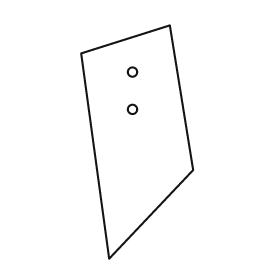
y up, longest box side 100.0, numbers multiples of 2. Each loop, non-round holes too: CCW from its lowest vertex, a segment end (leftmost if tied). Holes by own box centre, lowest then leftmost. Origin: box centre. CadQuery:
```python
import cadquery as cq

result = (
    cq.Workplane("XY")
    .moveTo(-12.0, -50.0)
    .lineTo(24.0, -12.0)
    .lineTo(14.0, 50.0)
    .lineTo(-24.0, 38.0)
    .close()
    .moveTo(-2.0, 14.0)
    .circle(2.0)
    .moveTo(-2.0, 30.0)
    .circle(2.0)
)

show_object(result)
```